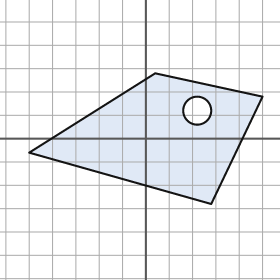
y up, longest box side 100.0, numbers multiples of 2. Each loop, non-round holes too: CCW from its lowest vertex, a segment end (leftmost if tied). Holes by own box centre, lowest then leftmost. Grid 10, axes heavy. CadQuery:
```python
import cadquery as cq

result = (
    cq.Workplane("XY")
    .moveTo(28.0, -28.0)
    .lineTo(50.0, 18.0)
    .lineTo(4.0, 28.0)
    .lineTo(-50.0, -6.0)
    .close()
    .moveTo(22.0, 12.0)
    .circle(6.0)
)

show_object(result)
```